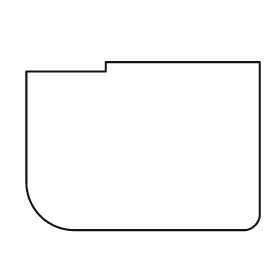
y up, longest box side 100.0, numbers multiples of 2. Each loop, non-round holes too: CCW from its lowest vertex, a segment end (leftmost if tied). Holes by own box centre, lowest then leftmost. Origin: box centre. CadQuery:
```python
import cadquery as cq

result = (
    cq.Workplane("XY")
    .moveTo(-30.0, -36.0)
    .lineTo(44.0, -36.0)
    .threePointArc((48.0, -34.0), (50.0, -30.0))
    .lineTo(50.0, 36.0)
    .lineTo(-16.0, 36.0)
    .lineTo(-16.0, 32.0)
    .lineTo(-50.0, 32.0)
    .lineTo(-50.0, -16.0)
    .threePointArc((-44.0, -30.0), (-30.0, -36.0))
    .close()
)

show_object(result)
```